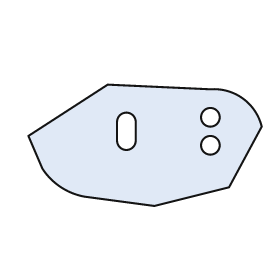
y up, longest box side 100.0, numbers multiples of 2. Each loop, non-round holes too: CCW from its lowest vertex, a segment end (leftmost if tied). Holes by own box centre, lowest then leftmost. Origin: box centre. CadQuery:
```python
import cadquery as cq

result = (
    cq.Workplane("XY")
    .moveTo(4.0, -26.0)
    .lineTo(36.0, -18.0)
    .lineTo(50.0, 8.0)
    .threePointArc((42.0, 20.0), (28.0, 24.0))
    .lineTo(-16.0, 26.0)
    .lineTo(-50.0, 4.0)
    .lineTo(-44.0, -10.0)
    .threePointArc((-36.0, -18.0), (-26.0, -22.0))
    .close()
    .moveTo(28.0, 0.0)
    .circle(4.0)
    .moveTo(-12.0, 2.0)
    .threePointArc((-8.0, -2.0), (-4.0, 2.0))
    .lineTo(-4.0, 10.0)
    .threePointArc((-8.0, 14.0), (-12.0, 10.0))
    .close()
    .moveTo(28.0, 12.0)
    .circle(4.0)
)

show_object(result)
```